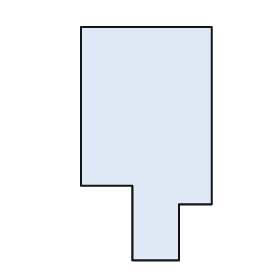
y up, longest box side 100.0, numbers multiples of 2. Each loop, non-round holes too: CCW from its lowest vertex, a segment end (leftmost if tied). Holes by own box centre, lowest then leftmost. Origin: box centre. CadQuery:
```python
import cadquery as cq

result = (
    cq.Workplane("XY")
    .moveTo(-6.0, -50.0)
    .lineTo(14.0, -50.0)
    .lineTo(14.0, -26.0)
    .lineTo(28.0, -26.0)
    .lineTo(28.0, 50.0)
    .lineTo(-28.0, 50.0)
    .lineTo(-28.0, -18.0)
    .lineTo(-6.0, -18.0)
    .close()
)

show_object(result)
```